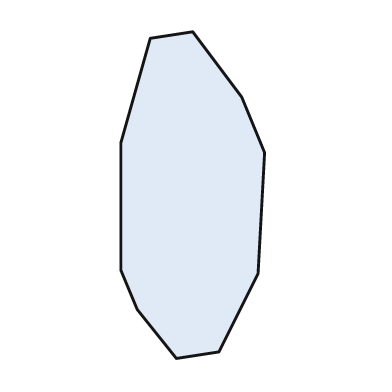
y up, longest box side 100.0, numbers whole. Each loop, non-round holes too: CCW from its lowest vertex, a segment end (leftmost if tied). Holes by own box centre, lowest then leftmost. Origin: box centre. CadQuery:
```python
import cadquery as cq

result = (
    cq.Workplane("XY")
    .moveTo(-5.0, -50.0)
    .lineTo(8.0, -48.0)
    .lineTo(20.0, -24.0)
    .lineTo(22.0, 13.0)
    .lineTo(15.0, 30.0)
    .lineTo(0.0, 50.0)
    .lineTo(-13.0, 48.0)
    .lineTo(-22.0, 16.0)
    .lineTo(-22.0, -23.0)
    .lineTo(-17.0, -35.0)
    .close()
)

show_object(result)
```